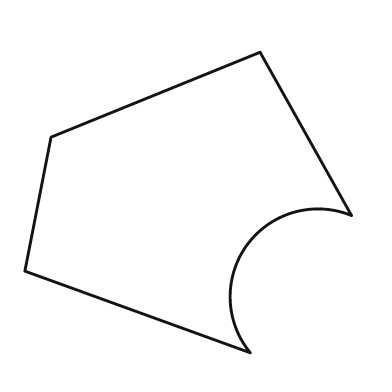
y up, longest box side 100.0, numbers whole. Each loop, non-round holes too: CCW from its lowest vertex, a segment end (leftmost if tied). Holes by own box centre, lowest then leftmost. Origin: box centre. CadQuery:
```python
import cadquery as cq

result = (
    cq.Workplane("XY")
    .moveTo(19.0, -46.0)
    .threePointArc((18.0, -13.0), (50.0, -4.0))
    .lineTo(22.0, 46.0)
    .lineTo(-42.0, 20.0)
    .lineTo(-50.0, -21.0)
    .close()
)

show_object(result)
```